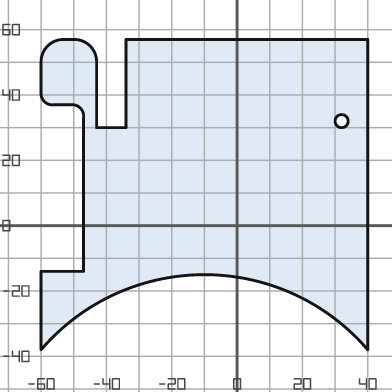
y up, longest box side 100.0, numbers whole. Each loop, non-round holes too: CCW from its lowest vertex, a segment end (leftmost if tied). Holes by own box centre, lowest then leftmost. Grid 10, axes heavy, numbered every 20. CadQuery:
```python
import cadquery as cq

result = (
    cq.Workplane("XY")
    .moveTo(-60.0, -38.0)
    .threePointArc((-10.0, -15.0), (40.0, -38.0))
    .lineTo(40.0, 57.0)
    .lineTo(-34.0, 57.0)
    .lineTo(-34.0, 30.0)
    .lineTo(-43.0, 30.0)
    .lineTo(-43.0, 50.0)
    .threePointArc((-45.0, 55.0), (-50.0, 57.0))
    .lineTo(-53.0, 57.0)
    .threePointArc((-58.0, 55.0), (-60.0, 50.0))
    .lineTo(-60.0, 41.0)
    .threePointArc((-59.0, 38.0), (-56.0, 37.0))
    .lineTo(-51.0, 37.0)
    .threePointArc((-48.0, 36.0), (-47.0, 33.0))
    .lineTo(-47.0, -14.0)
    .lineTo(-60.0, -14.0)
    .close()
    .moveTo(32.0, 32.0)
    .circle(2.0)
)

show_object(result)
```